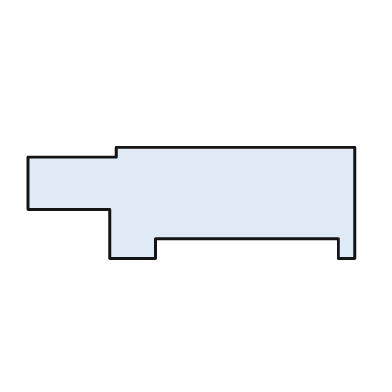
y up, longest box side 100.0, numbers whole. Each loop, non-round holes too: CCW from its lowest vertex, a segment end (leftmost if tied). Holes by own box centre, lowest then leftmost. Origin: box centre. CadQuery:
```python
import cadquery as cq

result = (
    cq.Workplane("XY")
    .moveTo(-25.0, -17.0)
    .lineTo(-11.0, -17.0)
    .lineTo(-11.0, -11.0)
    .lineTo(45.0, -11.0)
    .lineTo(45.0, -17.0)
    .lineTo(50.0, -17.0)
    .lineTo(50.0, 17.0)
    .lineTo(-23.0, 17.0)
    .lineTo(-23.0, 14.0)
    .lineTo(-50.0, 14.0)
    .lineTo(-50.0, -2.0)
    .lineTo(-25.0, -2.0)
    .close()
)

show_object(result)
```